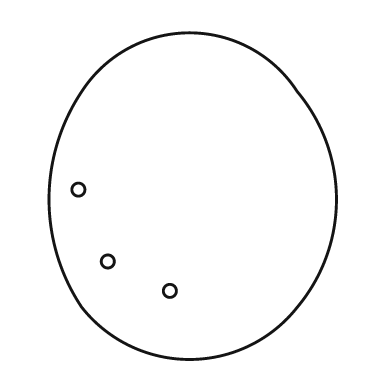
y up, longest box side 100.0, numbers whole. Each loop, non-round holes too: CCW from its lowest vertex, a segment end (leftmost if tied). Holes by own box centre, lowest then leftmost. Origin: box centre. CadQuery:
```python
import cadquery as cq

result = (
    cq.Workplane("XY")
    .moveTo(-34.0, -34.0)
    .threePointArc((-1.0, -50.0), (32.0, -34.0))
    .threePointArc((44.0, -1.0), (32.0, 32.0))
    .threePointArc((-1.0, 50.0), (-34.0, 32.0))
    .threePointArc((-44.0, -1.0), (-34.0, -34.0))
    .close()
    .moveTo(-7.0, -29.0)
    .circle(2.0)
    .moveTo(-26.0, -20.0)
    .circle(2.0)
    .moveTo(-35.0, 2.0)
    .circle(2.0)
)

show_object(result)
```